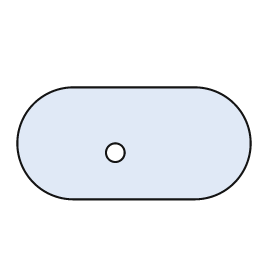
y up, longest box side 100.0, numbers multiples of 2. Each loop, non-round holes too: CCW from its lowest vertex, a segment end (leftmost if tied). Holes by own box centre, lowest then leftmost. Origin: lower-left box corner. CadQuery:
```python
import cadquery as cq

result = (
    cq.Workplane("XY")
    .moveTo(24.0, 0.0)
    .lineTo(76.0, 0.0)
    .threePointArc((100.0, 24.0), (76.0, 48.0))
    .lineTo(24.0, 48.0)
    .threePointArc((0.0, 24.0), (24.0, 0.0))
    .close()
    .moveTo(42.0, 20.0)
    .circle(4.0)
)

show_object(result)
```